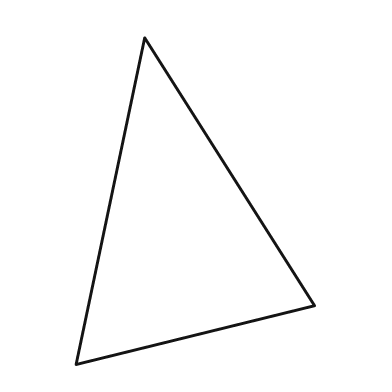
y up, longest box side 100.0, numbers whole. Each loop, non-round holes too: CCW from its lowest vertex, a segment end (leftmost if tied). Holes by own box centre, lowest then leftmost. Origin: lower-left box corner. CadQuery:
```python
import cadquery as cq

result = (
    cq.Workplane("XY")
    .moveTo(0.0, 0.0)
    .lineTo(73.0, 18.0)
    .lineTo(21.0, 100.0)
    .close()
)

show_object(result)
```